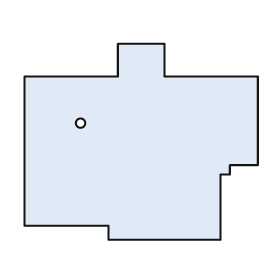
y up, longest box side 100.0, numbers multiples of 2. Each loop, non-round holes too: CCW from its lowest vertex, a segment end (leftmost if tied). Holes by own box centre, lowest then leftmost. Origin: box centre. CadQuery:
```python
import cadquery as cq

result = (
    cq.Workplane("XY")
    .moveTo(-14.0, -42.0)
    .lineTo(34.0, -42.0)
    .lineTo(34.0, -14.0)
    .lineTo(38.0, -14.0)
    .lineTo(38.0, -10.0)
    .lineTo(50.0, -10.0)
    .lineTo(50.0, 28.0)
    .lineTo(10.0, 28.0)
    .lineTo(10.0, 42.0)
    .lineTo(-10.0, 42.0)
    .lineTo(-10.0, 28.0)
    .lineTo(-50.0, 28.0)
    .lineTo(-50.0, -36.0)
    .lineTo(-14.0, -36.0)
    .close()
    .moveTo(-26.0, 8.0)
    .circle(2.0)
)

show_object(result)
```